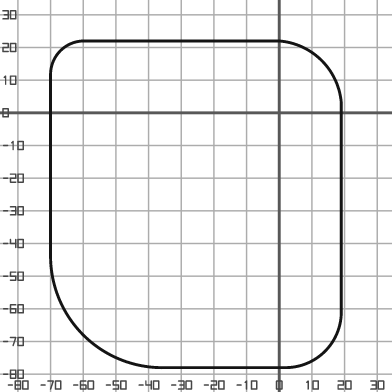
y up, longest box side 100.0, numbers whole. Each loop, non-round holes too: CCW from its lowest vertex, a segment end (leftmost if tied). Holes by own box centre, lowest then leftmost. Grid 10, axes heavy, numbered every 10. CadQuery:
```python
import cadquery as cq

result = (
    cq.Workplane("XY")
    .moveTo(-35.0, -78.0)
    .lineTo(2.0, -78.0)
    .threePointArc((14.0, -73.0), (19.0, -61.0))
    .lineTo(19.0, 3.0)
    .threePointArc((13.0, 16.0), (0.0, 22.0))
    .lineTo(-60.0, 22.0)
    .threePointArc((-67.0, 19.0), (-70.0, 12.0))
    .lineTo(-70.0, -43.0)
    .threePointArc((-60.0, -68.0), (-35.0, -78.0))
    .close()
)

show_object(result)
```